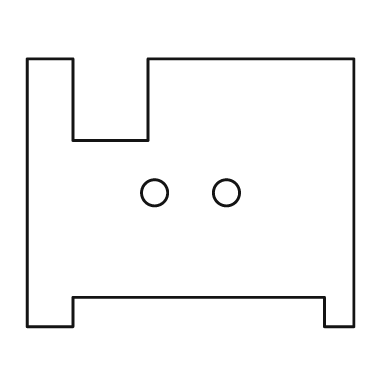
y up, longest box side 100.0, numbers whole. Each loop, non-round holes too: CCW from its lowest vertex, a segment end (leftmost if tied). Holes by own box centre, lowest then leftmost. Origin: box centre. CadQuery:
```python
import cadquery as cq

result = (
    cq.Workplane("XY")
    .moveTo(-50.0, -41.0)
    .lineTo(-36.0, -41.0)
    .lineTo(-36.0, -32.0)
    .lineTo(41.0, -32.0)
    .lineTo(41.0, -41.0)
    .lineTo(50.0, -41.0)
    .lineTo(50.0, 41.0)
    .lineTo(-13.0, 41.0)
    .lineTo(-13.0, 16.0)
    .lineTo(-36.0, 16.0)
    .lineTo(-36.0, 41.0)
    .lineTo(-50.0, 41.0)
    .close()
    .moveTo(-11.0, 0.0)
    .circle(4.0)
    .moveTo(11.0, 0.0)
    .circle(4.0)
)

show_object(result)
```